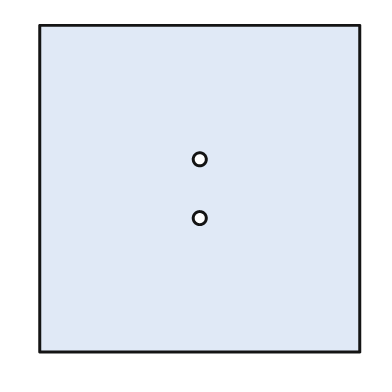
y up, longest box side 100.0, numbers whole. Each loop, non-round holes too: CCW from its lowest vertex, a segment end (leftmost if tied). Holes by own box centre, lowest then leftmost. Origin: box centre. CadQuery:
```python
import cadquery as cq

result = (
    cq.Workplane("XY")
    .moveTo(-49.0, -50.0)
    .lineTo(49.0, -50.0)
    .lineTo(49.0, 50.0)
    .lineTo(-49.0, 50.0)
    .close()
    .moveTo(0.0, -9.0)
    .circle(2.0)
    .moveTo(0.0, 9.0)
    .circle(2.0)
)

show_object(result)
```